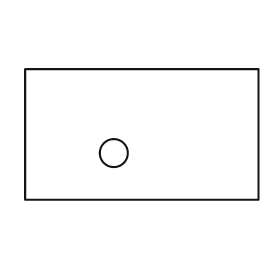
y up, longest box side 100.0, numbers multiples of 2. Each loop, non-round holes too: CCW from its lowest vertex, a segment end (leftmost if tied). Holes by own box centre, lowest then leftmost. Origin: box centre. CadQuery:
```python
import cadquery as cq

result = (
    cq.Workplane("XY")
    .moveTo(-50.0, -28.0)
    .lineTo(50.0, -28.0)
    .lineTo(50.0, 28.0)
    .lineTo(-50.0, 28.0)
    .close()
    .moveTo(-12.0, -8.0)
    .circle(6.0)
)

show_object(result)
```